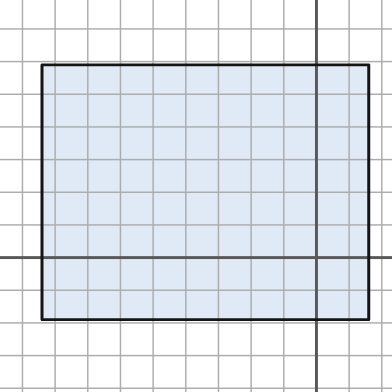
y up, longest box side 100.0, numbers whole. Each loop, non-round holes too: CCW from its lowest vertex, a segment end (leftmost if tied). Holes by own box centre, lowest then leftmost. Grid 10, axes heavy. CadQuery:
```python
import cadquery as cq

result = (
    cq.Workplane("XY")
    .moveTo(-84.0, -19.0)
    .lineTo(16.0, -19.0)
    .lineTo(16.0, 59.0)
    .lineTo(-84.0, 59.0)
    .close()
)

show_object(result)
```